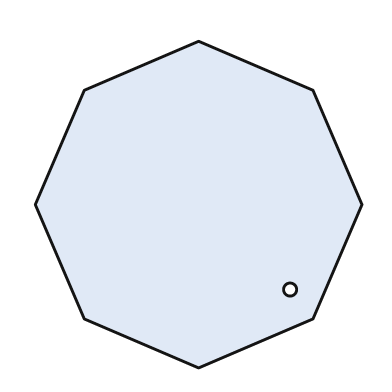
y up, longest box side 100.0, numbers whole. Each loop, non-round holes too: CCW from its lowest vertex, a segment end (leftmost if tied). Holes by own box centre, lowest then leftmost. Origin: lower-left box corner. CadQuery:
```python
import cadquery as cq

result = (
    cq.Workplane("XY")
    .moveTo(50.0, 0.0)
    .lineTo(85.0, 15.0)
    .lineTo(100.0, 50.0)
    .lineTo(85.0, 85.0)
    .lineTo(50.0, 100.0)
    .lineTo(15.0, 85.0)
    .lineTo(0.0, 50.0)
    .lineTo(15.0, 15.0)
    .close()
    .moveTo(78.0, 24.0)
    .circle(2.0)
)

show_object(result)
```